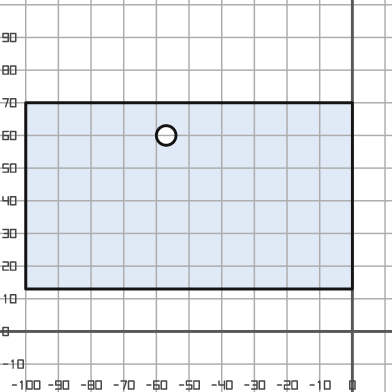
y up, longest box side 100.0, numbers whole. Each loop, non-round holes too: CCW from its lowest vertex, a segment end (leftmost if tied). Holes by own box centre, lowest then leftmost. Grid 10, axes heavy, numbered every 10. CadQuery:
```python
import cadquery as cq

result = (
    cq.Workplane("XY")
    .moveTo(-100.0, 13.0)
    .lineTo(0.0, 13.0)
    .lineTo(0.0, 70.0)
    .lineTo(-100.0, 70.0)
    .close()
    .moveTo(-57.0, 60.0)
    .circle(3.0)
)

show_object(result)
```